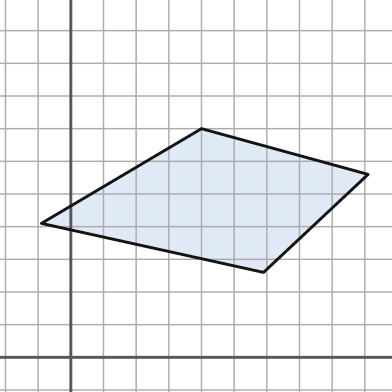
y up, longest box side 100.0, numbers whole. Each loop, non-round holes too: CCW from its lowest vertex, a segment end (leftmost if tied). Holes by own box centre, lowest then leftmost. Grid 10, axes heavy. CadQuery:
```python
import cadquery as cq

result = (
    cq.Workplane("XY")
    .moveTo(59.0, 26.0)
    .lineTo(91.0, 56.0)
    .lineTo(40.0, 70.0)
    .lineTo(-9.0, 41.0)
    .close()
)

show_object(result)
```